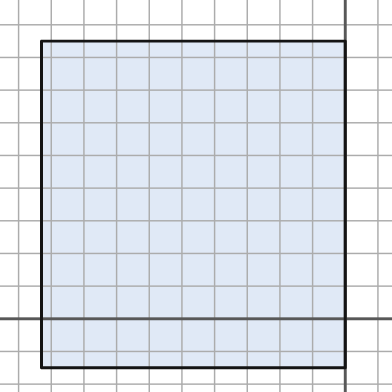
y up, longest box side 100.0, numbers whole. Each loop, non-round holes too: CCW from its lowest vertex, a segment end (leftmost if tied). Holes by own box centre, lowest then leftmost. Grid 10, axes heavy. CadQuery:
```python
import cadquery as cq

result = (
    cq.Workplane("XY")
    .moveTo(-93.0, -15.0)
    .lineTo(0.0, -15.0)
    .lineTo(0.0, 85.0)
    .lineTo(-93.0, 85.0)
    .close()
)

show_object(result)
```